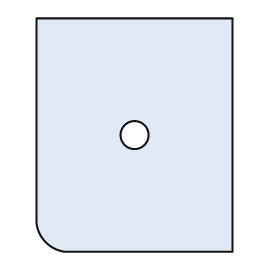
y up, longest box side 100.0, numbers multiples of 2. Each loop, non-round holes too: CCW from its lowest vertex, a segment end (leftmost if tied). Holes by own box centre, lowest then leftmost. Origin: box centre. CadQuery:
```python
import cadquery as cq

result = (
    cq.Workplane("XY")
    .moveTo(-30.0, -50.0)
    .lineTo(42.0, -50.0)
    .lineTo(42.0, 50.0)
    .lineTo(-42.0, 50.0)
    .lineTo(-42.0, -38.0)
    .threePointArc((-38.0, -46.0), (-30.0, -50.0))
    .close()
    .moveTo(0.0, 0.0)
    .circle(6.0)
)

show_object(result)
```